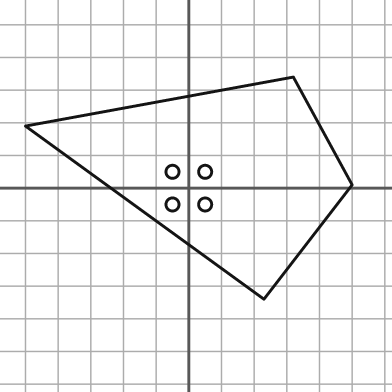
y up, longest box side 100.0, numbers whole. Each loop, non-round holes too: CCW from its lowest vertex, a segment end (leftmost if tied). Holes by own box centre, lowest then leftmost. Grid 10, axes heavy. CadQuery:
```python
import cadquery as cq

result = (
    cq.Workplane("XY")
    .moveTo(23.0, -34.0)
    .lineTo(50.0, 1.0)
    .lineTo(32.0, 34.0)
    .lineTo(-50.0, 19.0)
    .close()
    .moveTo(-5.0, -5.0)
    .circle(2.0)
    .moveTo(5.0, -5.0)
    .circle(2.0)
    .moveTo(-5.0, 5.0)
    .circle(2.0)
    .moveTo(5.0, 5.0)
    .circle(2.0)
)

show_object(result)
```